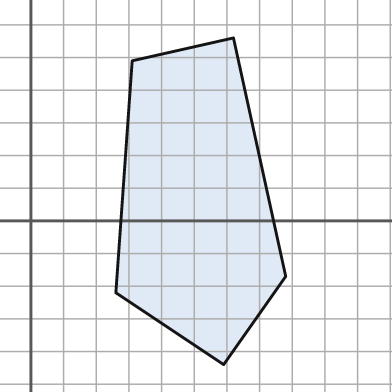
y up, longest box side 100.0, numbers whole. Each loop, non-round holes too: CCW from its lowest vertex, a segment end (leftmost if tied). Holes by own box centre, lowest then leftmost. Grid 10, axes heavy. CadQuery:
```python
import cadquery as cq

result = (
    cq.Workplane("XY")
    .moveTo(59.0, -44.0)
    .lineTo(78.0, -17.0)
    .lineTo(62.0, 56.0)
    .lineTo(31.0, 49.0)
    .lineTo(26.0, -22.0)
    .close()
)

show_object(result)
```